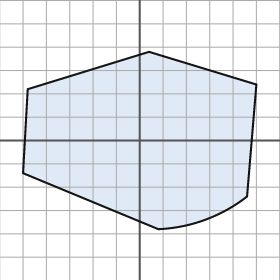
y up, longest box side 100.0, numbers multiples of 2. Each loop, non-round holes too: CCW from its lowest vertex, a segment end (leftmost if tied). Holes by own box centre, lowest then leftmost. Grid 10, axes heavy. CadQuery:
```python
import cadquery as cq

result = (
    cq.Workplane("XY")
    .moveTo(8.0, -38.0)
    .threePointArc((28.0, -34.0), (46.0, -24.0))
    .lineTo(50.0, 24.0)
    .lineTo(4.0, 38.0)
    .lineTo(-48.0, 22.0)
    .lineTo(-50.0, -14.0)
    .close()
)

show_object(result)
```